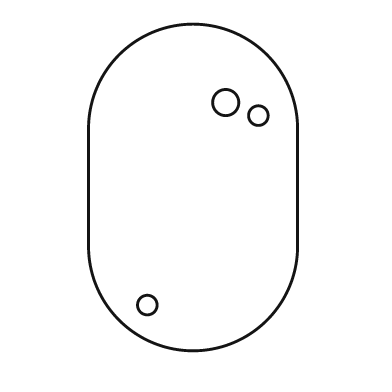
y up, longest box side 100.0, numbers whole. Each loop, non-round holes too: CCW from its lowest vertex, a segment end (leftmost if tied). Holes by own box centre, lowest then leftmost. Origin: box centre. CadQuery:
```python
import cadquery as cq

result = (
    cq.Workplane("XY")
    .moveTo(-32.0, -18.0)
    .threePointArc((0.0, -50.0), (32.0, -18.0))
    .lineTo(32.0, 18.0)
    .threePointArc((0.0, 50.0), (-32.0, 18.0))
    .close()
    .moveTo(-14.0, -36.0)
    .circle(3.0)
    .moveTo(20.0, 22.0)
    .circle(3.0)
    .moveTo(10.0, 26.0)
    .circle(4.0)
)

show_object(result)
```